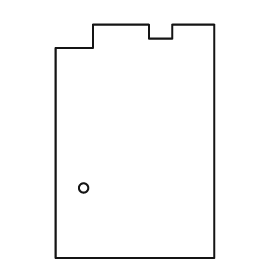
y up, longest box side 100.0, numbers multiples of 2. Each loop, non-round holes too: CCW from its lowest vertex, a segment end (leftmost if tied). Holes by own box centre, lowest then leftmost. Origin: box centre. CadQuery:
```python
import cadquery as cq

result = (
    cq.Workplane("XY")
    .moveTo(-34.0, -50.0)
    .lineTo(34.0, -50.0)
    .lineTo(34.0, 50.0)
    .lineTo(16.0, 50.0)
    .lineTo(16.0, 44.0)
    .lineTo(6.0, 44.0)
    .lineTo(6.0, 50.0)
    .lineTo(-18.0, 50.0)
    .lineTo(-18.0, 40.0)
    .lineTo(-34.0, 40.0)
    .close()
    .moveTo(-22.0, -20.0)
    .circle(2.0)
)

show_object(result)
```